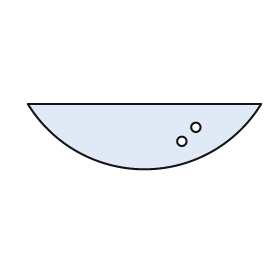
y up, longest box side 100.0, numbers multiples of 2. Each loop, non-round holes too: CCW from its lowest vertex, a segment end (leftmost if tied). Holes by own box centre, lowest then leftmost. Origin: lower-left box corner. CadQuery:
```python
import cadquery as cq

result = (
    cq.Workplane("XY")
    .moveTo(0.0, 28.0)
    .threePointArc((50.0, 0.0), (100.0, 28.0))
    .close()
    .moveTo(66.0, 12.0)
    .circle(2.0)
    .moveTo(72.0, 18.0)
    .circle(2.0)
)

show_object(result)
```